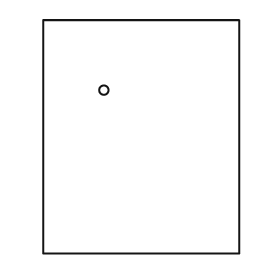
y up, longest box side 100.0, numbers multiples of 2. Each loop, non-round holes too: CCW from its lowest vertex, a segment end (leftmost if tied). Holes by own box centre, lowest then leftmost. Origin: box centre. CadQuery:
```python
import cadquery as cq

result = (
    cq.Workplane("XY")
    .moveTo(-42.0, -50.0)
    .lineTo(42.0, -50.0)
    .lineTo(42.0, 50.0)
    .lineTo(-42.0, 50.0)
    .close()
    .moveTo(-16.0, 20.0)
    .circle(2.0)
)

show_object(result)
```